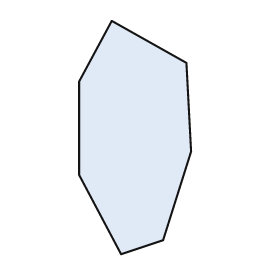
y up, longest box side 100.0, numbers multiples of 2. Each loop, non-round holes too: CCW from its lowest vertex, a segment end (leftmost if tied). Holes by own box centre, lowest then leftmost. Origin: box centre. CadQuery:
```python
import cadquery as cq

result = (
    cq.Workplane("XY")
    .moveTo(-6.0, -50.0)
    .lineTo(12.0, -44.0)
    .lineTo(24.0, -6.0)
    .lineTo(22.0, 32.0)
    .lineTo(-10.0, 50.0)
    .lineTo(-24.0, 24.0)
    .lineTo(-24.0, -16.0)
    .close()
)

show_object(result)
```